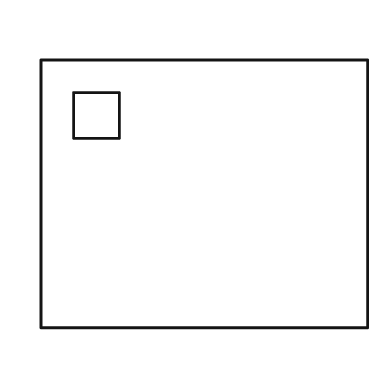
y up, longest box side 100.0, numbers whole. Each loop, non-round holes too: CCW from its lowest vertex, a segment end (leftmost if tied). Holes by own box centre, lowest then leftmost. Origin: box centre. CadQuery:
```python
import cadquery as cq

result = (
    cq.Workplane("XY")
    .moveTo(-50.0, -41.0)
    .lineTo(50.0, -41.0)
    .lineTo(50.0, 41.0)
    .lineTo(-50.0, 41.0)
    .close()
    .moveTo(-40.0, 17.0)
    .lineTo(-26.0, 17.0)
    .lineTo(-26.0, 31.0)
    .lineTo(-40.0, 31.0)
    .close()
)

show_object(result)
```